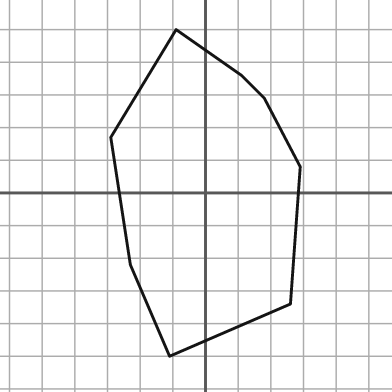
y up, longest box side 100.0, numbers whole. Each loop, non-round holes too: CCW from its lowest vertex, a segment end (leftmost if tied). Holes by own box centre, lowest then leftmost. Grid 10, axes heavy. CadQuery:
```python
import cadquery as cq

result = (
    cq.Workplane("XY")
    .moveTo(-11.0, -50.0)
    .lineTo(26.0, -34.0)
    .lineTo(29.0, 8.0)
    .lineTo(18.0, 29.0)
    .lineTo(11.0, 36.0)
    .lineTo(-9.0, 50.0)
    .lineTo(-29.0, 17.0)
    .lineTo(-23.0, -22.0)
    .close()
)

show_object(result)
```